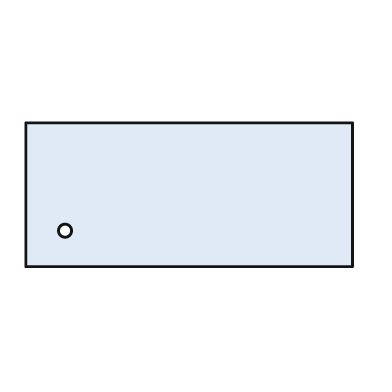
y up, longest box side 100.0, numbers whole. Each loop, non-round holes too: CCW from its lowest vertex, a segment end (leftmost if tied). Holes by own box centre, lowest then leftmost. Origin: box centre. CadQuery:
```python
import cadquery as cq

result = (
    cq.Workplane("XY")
    .moveTo(-50.0, -22.0)
    .lineTo(50.0, -22.0)
    .lineTo(50.0, 22.0)
    .lineTo(-50.0, 22.0)
    .close()
    .moveTo(-38.0, -11.0)
    .circle(2.0)
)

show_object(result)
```